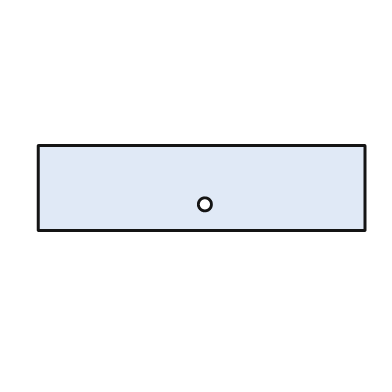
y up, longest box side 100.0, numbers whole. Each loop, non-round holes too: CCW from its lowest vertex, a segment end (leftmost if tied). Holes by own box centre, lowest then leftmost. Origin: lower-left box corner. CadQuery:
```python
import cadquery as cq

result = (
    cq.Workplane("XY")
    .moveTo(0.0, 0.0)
    .lineTo(100.0, 0.0)
    .lineTo(100.0, 26.0)
    .lineTo(0.0, 26.0)
    .close()
    .moveTo(51.0, 8.0)
    .circle(2.0)
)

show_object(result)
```